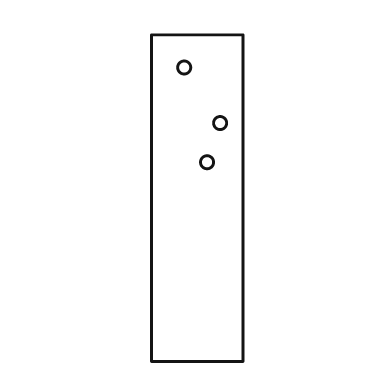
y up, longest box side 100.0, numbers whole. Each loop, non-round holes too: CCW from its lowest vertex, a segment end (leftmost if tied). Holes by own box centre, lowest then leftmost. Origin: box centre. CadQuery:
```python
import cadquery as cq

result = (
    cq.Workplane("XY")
    .moveTo(-14.0, -50.0)
    .lineTo(14.0, -50.0)
    .lineTo(14.0, 50.0)
    .lineTo(-14.0, 50.0)
    .close()
    .moveTo(3.0, 11.0)
    .circle(2.0)
    .moveTo(7.0, 23.0)
    .circle(2.0)
    .moveTo(-4.0, 40.0)
    .circle(2.0)
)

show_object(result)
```